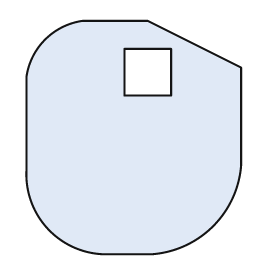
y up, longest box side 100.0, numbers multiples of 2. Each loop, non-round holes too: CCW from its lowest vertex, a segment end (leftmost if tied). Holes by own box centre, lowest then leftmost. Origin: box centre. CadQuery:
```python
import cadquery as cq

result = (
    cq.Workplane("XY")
    .moveTo(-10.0, -50.0)
    .lineTo(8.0, -50.0)
    .threePointArc((34.0, -38.0), (46.0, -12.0))
    .lineTo(46.0, 30.0)
    .lineTo(6.0, 50.0)
    .lineTo(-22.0, 50.0)
    .threePointArc((-38.0, 42.0), (-46.0, 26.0))
    .lineTo(-46.0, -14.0)
    .threePointArc((-36.0, -40.0), (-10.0, -50.0))
    .close()
    .moveTo(-4.0, 18.0)
    .lineTo(16.0, 18.0)
    .lineTo(16.0, 38.0)
    .lineTo(-4.0, 38.0)
    .close()
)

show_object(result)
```